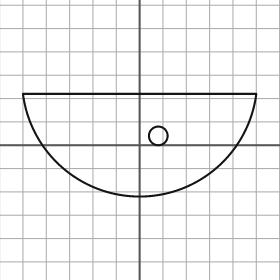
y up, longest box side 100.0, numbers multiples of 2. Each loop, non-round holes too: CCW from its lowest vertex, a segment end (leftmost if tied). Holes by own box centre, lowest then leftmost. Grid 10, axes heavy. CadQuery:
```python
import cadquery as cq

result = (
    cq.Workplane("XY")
    .moveTo(-50.0, 22.0)
    .threePointArc((0.0, -22.0), (50.0, 22.0))
    .close()
    .moveTo(8.0, 4.0)
    .circle(4.0)
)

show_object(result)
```